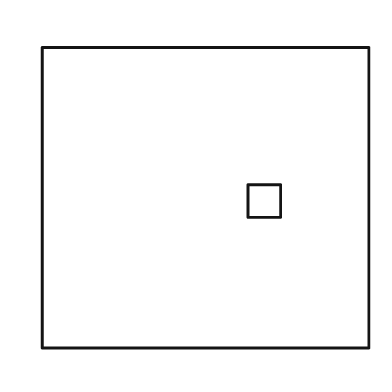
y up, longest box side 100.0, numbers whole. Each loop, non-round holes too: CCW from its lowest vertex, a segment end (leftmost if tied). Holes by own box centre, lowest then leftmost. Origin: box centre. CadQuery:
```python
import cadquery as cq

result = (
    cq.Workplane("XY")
    .moveTo(-50.0, -46.0)
    .lineTo(50.0, -46.0)
    .lineTo(50.0, 46.0)
    .lineTo(-50.0, 46.0)
    .close()
    .moveTo(13.0, -6.0)
    .lineTo(23.0, -6.0)
    .lineTo(23.0, 4.0)
    .lineTo(13.0, 4.0)
    .close()
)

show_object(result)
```